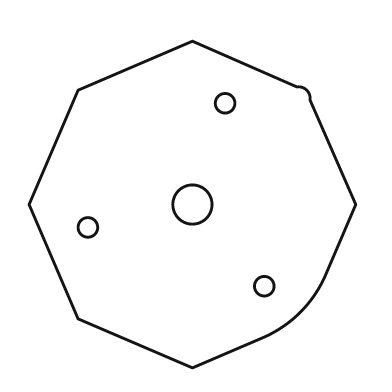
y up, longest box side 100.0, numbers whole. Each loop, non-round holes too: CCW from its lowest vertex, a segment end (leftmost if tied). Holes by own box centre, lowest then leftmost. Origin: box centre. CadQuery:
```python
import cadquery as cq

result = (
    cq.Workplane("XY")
    .moveTo(0.0, -50.0)
    .lineTo(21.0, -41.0)
    .threePointArc((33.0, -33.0), (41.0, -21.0))
    .lineTo(50.0, 0.0)
    .lineTo(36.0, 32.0)
    .threePointArc((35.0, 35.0), (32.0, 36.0))
    .lineTo(0.0, 50.0)
    .lineTo(-35.0, 35.0)
    .lineTo(-50.0, 0.0)
    .lineTo(-35.0, -35.0)
    .close()
    .moveTo(22.0, -25.0)
    .circle(3.0)
    .moveTo(-32.0, -7.0)
    .circle(3.0)
    .moveTo(0.0, 0.0)
    .circle(6.0)
    .moveTo(10.0, 31.0)
    .circle(3.0)
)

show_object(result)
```